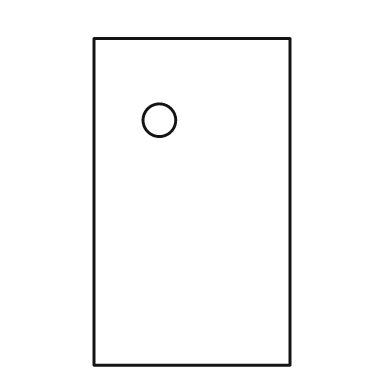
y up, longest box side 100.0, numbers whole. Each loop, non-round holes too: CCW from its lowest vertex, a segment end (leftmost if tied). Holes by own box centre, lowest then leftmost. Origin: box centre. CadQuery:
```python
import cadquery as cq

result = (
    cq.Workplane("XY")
    .moveTo(-30.0, -50.0)
    .lineTo(30.0, -50.0)
    .lineTo(30.0, 50.0)
    .lineTo(-30.0, 50.0)
    .close()
    .moveTo(-10.0, 25.0)
    .circle(5.0)
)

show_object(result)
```